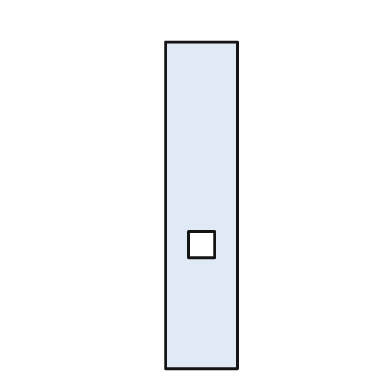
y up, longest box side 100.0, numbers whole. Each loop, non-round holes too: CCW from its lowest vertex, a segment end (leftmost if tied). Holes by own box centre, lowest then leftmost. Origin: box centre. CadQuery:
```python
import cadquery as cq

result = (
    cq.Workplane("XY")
    .moveTo(-11.0, -50.0)
    .lineTo(11.0, -50.0)
    .lineTo(11.0, 50.0)
    .lineTo(-11.0, 50.0)
    .close()
    .moveTo(-4.0, -16.0)
    .lineTo(4.0, -16.0)
    .lineTo(4.0, -8.0)
    .lineTo(-4.0, -8.0)
    .close()
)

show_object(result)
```